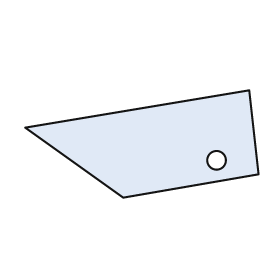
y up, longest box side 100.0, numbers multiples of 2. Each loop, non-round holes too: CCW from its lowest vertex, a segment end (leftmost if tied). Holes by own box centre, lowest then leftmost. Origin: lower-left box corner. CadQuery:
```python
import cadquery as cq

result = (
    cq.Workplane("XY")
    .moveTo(42.0, 0.0)
    .lineTo(100.0, 10.0)
    .lineTo(96.0, 46.0)
    .lineTo(0.0, 30.0)
    .close()
    .moveTo(82.0, 16.0)
    .circle(4.0)
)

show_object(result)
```